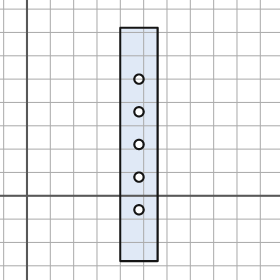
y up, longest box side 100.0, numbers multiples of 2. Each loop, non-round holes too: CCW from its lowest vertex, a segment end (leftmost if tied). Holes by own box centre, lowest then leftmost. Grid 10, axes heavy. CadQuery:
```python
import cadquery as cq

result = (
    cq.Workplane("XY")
    .moveTo(40.0, -28.0)
    .lineTo(56.0, -28.0)
    .lineTo(56.0, 72.0)
    .lineTo(40.0, 72.0)
    .close()
    .moveTo(48.0, -6.0)
    .circle(2.0)
    .moveTo(48.0, 8.0)
    .circle(2.0)
    .moveTo(48.0, 22.0)
    .circle(2.0)
    .moveTo(48.0, 36.0)
    .circle(2.0)
    .moveTo(48.0, 50.0)
    .circle(2.0)
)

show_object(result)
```